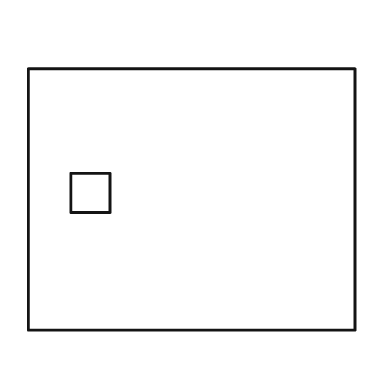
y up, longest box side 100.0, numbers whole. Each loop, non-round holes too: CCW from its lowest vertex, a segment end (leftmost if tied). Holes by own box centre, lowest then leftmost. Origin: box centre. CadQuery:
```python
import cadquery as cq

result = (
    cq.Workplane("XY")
    .moveTo(-50.0, -40.0)
    .lineTo(50.0, -40.0)
    .lineTo(50.0, 40.0)
    .lineTo(-50.0, 40.0)
    .close()
    .moveTo(-37.0, -4.0)
    .lineTo(-25.0, -4.0)
    .lineTo(-25.0, 8.0)
    .lineTo(-37.0, 8.0)
    .close()
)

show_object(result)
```